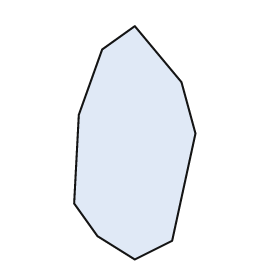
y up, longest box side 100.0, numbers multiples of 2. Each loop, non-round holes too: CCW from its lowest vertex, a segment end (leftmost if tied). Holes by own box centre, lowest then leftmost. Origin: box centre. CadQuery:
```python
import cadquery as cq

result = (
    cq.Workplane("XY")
    .moveTo(0.0, -50.0)
    .lineTo(16.0, -42.0)
    .lineTo(26.0, 4.0)
    .lineTo(20.0, 26.0)
    .lineTo(0.0, 50.0)
    .lineTo(-14.0, 40.0)
    .lineTo(-24.0, 12.0)
    .lineTo(-26.0, -26.0)
    .lineTo(-16.0, -40.0)
    .close()
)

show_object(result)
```